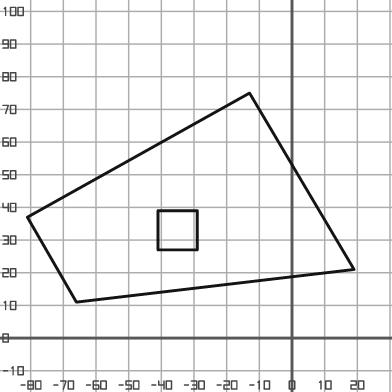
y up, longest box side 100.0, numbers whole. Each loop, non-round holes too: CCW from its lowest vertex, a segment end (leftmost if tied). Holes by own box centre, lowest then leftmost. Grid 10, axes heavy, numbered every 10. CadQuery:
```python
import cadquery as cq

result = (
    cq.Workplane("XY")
    .moveTo(-66.0, 11.0)
    .lineTo(19.0, 21.0)
    .lineTo(-13.0, 75.0)
    .lineTo(-81.0, 37.0)
    .close()
    .moveTo(-41.0, 27.0)
    .lineTo(-29.0, 27.0)
    .lineTo(-29.0, 39.0)
    .lineTo(-41.0, 39.0)
    .close()
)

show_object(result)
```